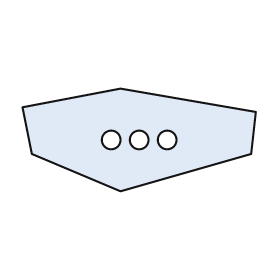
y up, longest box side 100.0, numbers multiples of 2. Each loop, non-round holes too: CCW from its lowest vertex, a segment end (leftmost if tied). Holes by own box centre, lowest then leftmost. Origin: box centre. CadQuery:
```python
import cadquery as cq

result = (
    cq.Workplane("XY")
    .moveTo(-8.0, -22.0)
    .lineTo(48.0, -6.0)
    .lineTo(50.0, 12.0)
    .lineTo(-8.0, 22.0)
    .lineTo(-50.0, 14.0)
    .lineTo(-46.0, -6.0)
    .close()
    .moveTo(-12.0, 0.0)
    .circle(4.0)
    .moveTo(0.0, 0.0)
    .circle(4.0)
    .moveTo(12.0, 0.0)
    .circle(4.0)
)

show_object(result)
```